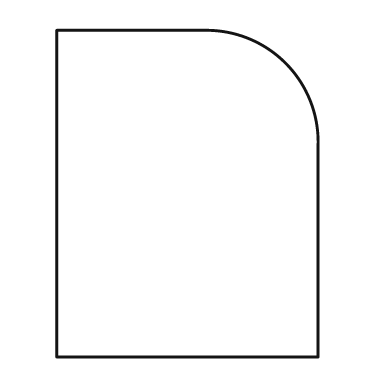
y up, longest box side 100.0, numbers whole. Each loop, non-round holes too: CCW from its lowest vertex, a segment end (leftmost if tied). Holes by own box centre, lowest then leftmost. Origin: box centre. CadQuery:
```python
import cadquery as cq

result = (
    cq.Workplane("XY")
    .moveTo(-40.0, -50.0)
    .lineTo(40.0, -50.0)
    .lineTo(40.0, 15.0)
    .threePointArc((30.0, 40.0), (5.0, 50.0))
    .lineTo(-40.0, 50.0)
    .close()
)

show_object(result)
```